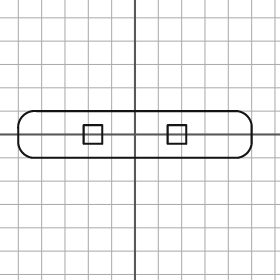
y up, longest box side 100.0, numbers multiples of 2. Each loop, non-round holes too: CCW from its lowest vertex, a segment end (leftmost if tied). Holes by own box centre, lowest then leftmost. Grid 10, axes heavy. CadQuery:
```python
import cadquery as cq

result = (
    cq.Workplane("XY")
    .moveTo(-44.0, -10.0)
    .lineTo(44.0, -10.0)
    .threePointArc((48.0, -8.0), (50.0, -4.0))
    .lineTo(50.0, 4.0)
    .threePointArc((48.0, 8.0), (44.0, 10.0))
    .lineTo(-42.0, 10.0)
    .threePointArc((-48.0, 8.0), (-50.0, 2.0))
    .lineTo(-50.0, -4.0)
    .threePointArc((-48.0, -8.0), (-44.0, -10.0))
    .close()
    .moveTo(-22.0, -4.0)
    .lineTo(-14.0, -4.0)
    .lineTo(-14.0, 4.0)
    .lineTo(-22.0, 4.0)
    .close()
    .moveTo(14.0, -4.0)
    .lineTo(22.0, -4.0)
    .lineTo(22.0, 4.0)
    .lineTo(14.0, 4.0)
    .close()
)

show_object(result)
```